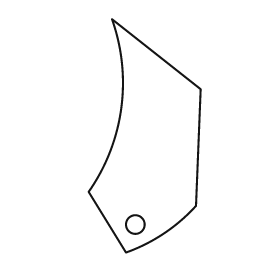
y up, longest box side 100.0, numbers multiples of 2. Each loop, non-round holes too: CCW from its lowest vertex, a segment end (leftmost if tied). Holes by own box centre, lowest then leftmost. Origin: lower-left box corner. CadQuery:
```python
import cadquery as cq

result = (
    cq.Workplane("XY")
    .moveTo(16.0, 0.0)
    .threePointArc((32.0, 8.0), (46.0, 20.0))
    .lineTo(48.0, 70.0)
    .lineTo(10.0, 100.0)
    .threePointArc((14.0, 62.0), (0.0, 26.0))
    .close()
    .moveTo(20.0, 12.0)
    .circle(4.0)
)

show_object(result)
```